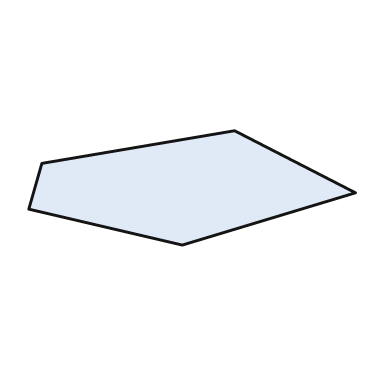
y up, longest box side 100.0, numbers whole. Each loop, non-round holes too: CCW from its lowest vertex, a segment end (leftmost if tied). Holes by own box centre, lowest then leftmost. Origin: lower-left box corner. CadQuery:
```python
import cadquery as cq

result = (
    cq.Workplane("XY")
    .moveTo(47.0, 0.0)
    .lineTo(100.0, 16.0)
    .lineTo(63.0, 35.0)
    .lineTo(4.0, 25.0)
    .lineTo(0.0, 11.0)
    .close()
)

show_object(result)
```